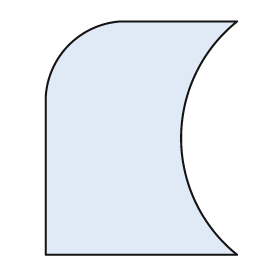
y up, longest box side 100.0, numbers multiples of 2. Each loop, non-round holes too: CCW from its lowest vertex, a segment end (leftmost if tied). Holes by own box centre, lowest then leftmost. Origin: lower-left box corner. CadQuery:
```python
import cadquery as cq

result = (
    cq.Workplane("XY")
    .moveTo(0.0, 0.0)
    .lineTo(82.0, 0.0)
    .threePointArc((58.0, 50.0), (82.0, 100.0))
    .lineTo(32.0, 100.0)
    .threePointArc((10.0, 90.0), (0.0, 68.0))
    .close()
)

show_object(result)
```